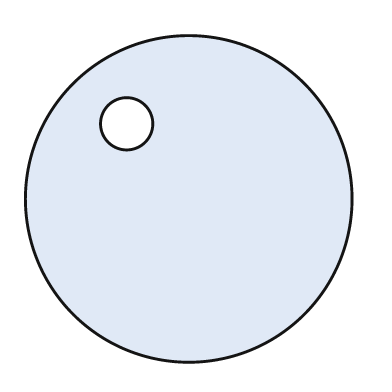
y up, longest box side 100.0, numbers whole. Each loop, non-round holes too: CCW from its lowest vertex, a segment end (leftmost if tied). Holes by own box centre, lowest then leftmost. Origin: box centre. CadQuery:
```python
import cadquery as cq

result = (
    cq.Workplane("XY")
    .moveTo(0.0, 0.0)
    .circle(50.0)
    .moveTo(-19.0, 23.0)
    .circle(8.0)
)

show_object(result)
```